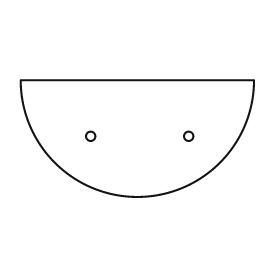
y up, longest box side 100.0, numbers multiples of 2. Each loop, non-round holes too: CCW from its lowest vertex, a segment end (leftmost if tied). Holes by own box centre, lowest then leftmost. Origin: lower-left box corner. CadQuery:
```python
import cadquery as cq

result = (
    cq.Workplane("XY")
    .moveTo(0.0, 50.0)
    .threePointArc((50.0, 0.0), (100.0, 50.0))
    .close()
    .moveTo(30.0, 26.0)
    .circle(2.0)
    .moveTo(72.0, 26.0)
    .circle(2.0)
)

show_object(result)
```